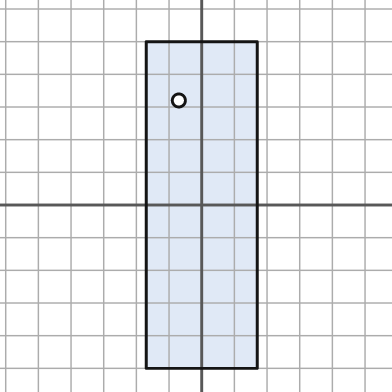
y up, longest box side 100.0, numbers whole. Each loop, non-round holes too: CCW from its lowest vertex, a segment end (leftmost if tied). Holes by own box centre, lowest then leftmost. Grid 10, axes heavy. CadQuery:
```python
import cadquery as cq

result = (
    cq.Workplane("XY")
    .moveTo(-17.0, -50.0)
    .lineTo(17.0, -50.0)
    .lineTo(17.0, 50.0)
    .lineTo(-17.0, 50.0)
    .close()
    .moveTo(-7.0, 32.0)
    .circle(2.0)
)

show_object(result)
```